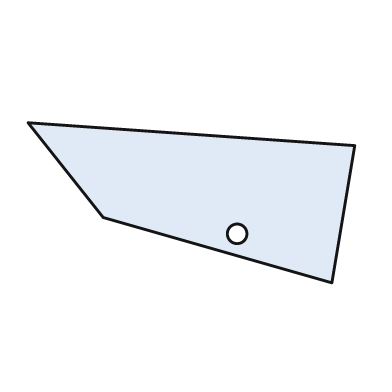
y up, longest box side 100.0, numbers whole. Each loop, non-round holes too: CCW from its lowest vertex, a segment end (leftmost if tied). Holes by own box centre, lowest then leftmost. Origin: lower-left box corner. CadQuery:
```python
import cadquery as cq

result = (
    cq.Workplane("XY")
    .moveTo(93.0, 0.0)
    .lineTo(100.0, 42.0)
    .lineTo(0.0, 49.0)
    .lineTo(23.0, 20.0)
    .close()
    .moveTo(64.0, 15.0)
    .circle(3.0)
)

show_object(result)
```